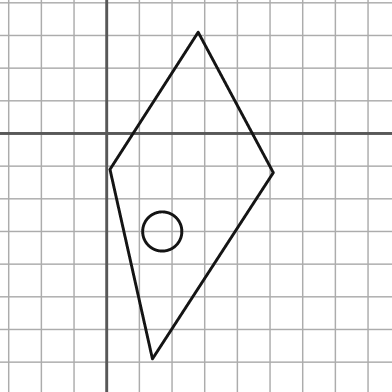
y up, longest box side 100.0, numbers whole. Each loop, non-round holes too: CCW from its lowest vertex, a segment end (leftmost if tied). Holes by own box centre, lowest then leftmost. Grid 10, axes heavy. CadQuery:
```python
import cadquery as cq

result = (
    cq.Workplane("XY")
    .moveTo(14.0, -69.0)
    .lineTo(51.0, -12.0)
    .lineTo(28.0, 31.0)
    .lineTo(1.0, -11.0)
    .close()
    .moveTo(17.0, -30.0)
    .circle(6.0)
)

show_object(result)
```